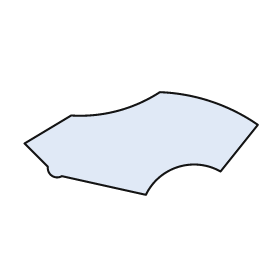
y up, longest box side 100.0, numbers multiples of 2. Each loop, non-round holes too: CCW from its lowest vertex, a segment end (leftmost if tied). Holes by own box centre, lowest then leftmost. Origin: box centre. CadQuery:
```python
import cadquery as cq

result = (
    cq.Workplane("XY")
    .moveTo(2.0, -22.0)
    .threePointArc((16.0, -10.0), (34.0, -12.0))
    .lineTo(50.0, 8.0)
    .threePointArc((30.0, 18.0), (8.0, 22.0))
    .threePointArc((-10.0, 14.0), (-30.0, 12.0))
    .lineTo(-50.0, 0.0)
    .lineTo(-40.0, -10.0)
    .threePointArc((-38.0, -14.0), (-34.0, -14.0))
    .close()
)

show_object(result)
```